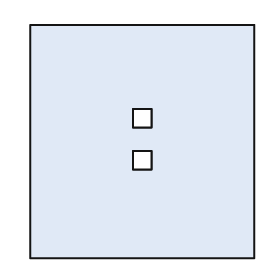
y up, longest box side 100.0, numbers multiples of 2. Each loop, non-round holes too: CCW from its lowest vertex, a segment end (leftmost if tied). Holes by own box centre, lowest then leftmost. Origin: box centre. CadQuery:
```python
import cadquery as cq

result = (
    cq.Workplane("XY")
    .moveTo(-48.0, -50.0)
    .lineTo(48.0, -50.0)
    .lineTo(48.0, 50.0)
    .lineTo(-48.0, 50.0)
    .close()
    .moveTo(-4.0, -12.0)
    .lineTo(4.0, -12.0)
    .lineTo(4.0, -4.0)
    .lineTo(-4.0, -4.0)
    .close()
    .moveTo(-4.0, 6.0)
    .lineTo(4.0, 6.0)
    .lineTo(4.0, 14.0)
    .lineTo(-4.0, 14.0)
    .close()
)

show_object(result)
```